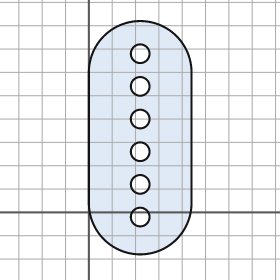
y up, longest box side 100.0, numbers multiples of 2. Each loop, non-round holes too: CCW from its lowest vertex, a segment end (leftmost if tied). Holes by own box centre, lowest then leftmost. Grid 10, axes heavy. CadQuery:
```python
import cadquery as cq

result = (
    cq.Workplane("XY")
    .moveTo(0.0, 4.0)
    .threePointArc((22.0, -18.0), (44.0, 4.0))
    .lineTo(44.0, 60.0)
    .threePointArc((22.0, 82.0), (0.0, 60.0))
    .close()
    .moveTo(22.0, -2.0)
    .circle(4.0)
    .moveTo(22.0, 12.0)
    .circle(4.0)
    .moveTo(22.0, 26.0)
    .circle(4.0)
    .moveTo(22.0, 40.0)
    .circle(4.0)
    .moveTo(22.0, 54.0)
    .circle(4.0)
    .moveTo(22.0, 68.0)
    .circle(4.0)
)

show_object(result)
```